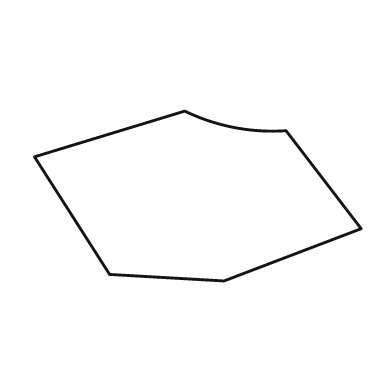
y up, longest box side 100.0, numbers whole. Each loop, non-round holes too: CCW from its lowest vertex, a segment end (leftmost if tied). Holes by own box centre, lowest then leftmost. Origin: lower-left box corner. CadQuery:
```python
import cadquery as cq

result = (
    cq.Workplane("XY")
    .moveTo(58.0, 0.0)
    .lineTo(100.0, 16.0)
    .lineTo(77.0, 46.0)
    .threePointArc((61.0, 47.0), (46.0, 52.0))
    .lineTo(0.0, 38.0)
    .lineTo(23.0, 2.0)
    .close()
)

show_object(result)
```